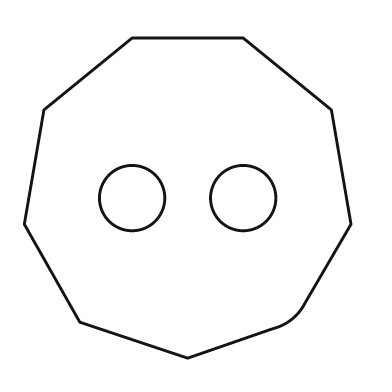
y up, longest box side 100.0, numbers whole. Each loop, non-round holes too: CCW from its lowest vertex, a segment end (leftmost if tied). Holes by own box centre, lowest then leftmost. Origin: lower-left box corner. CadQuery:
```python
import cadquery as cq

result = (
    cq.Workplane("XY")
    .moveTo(50.0, 0.0)
    .lineTo(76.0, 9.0)
    .threePointArc((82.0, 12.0), (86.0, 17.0))
    .lineTo(100.0, 41.0)
    .lineTo(94.0, 76.0)
    .lineTo(67.0, 98.0)
    .lineTo(33.0, 98.0)
    .lineTo(6.0, 76.0)
    .lineTo(0.0, 41.0)
    .lineTo(17.0, 11.0)
    .close()
    .moveTo(33.0, 49.0)
    .circle(10.0)
    .moveTo(67.0, 49.0)
    .circle(10.0)
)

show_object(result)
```